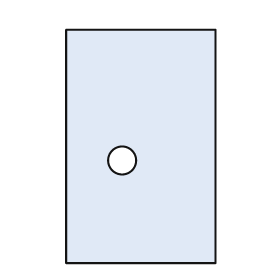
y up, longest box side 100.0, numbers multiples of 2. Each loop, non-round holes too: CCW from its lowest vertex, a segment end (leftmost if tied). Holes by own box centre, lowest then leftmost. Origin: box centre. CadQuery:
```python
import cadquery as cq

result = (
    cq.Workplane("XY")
    .moveTo(-32.0, -50.0)
    .lineTo(32.0, -50.0)
    .lineTo(32.0, 50.0)
    .lineTo(-32.0, 50.0)
    .close()
    .moveTo(-8.0, -6.0)
    .circle(6.0)
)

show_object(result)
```